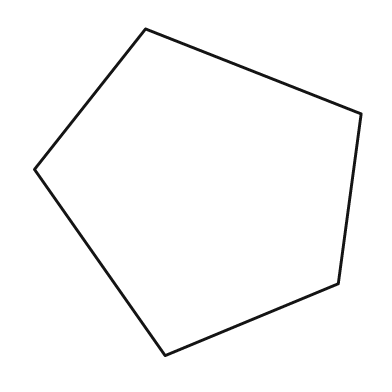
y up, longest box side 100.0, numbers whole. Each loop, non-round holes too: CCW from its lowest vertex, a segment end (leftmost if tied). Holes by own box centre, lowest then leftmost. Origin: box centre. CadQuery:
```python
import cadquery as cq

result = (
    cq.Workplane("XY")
    .moveTo(-10.0, -50.0)
    .lineTo(43.0, -28.0)
    .lineTo(50.0, 24.0)
    .lineTo(-16.0, 50.0)
    .lineTo(-50.0, 7.0)
    .close()
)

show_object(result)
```